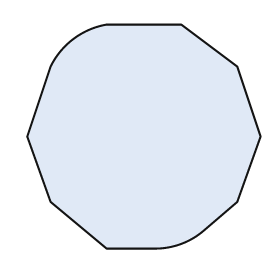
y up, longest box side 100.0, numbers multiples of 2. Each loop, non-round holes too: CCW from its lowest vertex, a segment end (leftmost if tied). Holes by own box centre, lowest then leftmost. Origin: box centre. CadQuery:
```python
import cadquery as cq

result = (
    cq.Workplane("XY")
    .moveTo(-16.0, -48.0)
    .lineTo(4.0, -48.0)
    .threePointArc((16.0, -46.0), (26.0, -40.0))
    .lineTo(40.0, -28.0)
    .lineTo(50.0, 0.0)
    .lineTo(40.0, 30.0)
    .lineTo(16.0, 48.0)
    .lineTo(-16.0, 48.0)
    .threePointArc((-30.0, 42.0), (-40.0, 30.0))
    .lineTo(-50.0, 0.0)
    .lineTo(-40.0, -28.0)
    .close()
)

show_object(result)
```